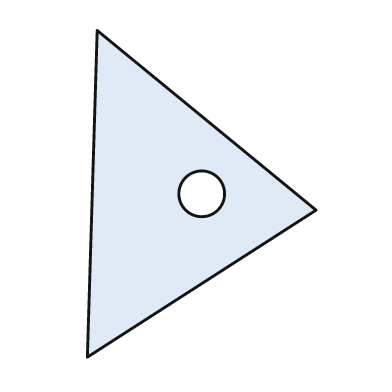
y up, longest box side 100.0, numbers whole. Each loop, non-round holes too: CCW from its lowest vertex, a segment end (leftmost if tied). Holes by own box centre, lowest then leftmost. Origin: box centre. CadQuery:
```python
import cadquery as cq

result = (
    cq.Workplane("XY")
    .moveTo(-35.0, -50.0)
    .lineTo(35.0, -5.0)
    .lineTo(-32.0, 50.0)
    .close()
    .moveTo(0.0, 0.0)
    .circle(7.0)
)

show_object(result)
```